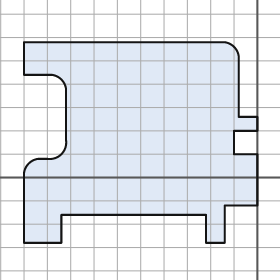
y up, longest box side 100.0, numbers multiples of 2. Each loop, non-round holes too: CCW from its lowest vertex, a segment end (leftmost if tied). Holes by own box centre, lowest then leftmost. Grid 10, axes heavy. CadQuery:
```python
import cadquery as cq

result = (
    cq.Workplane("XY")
    .moveTo(-100.0, -28.0)
    .lineTo(-84.0, -28.0)
    .lineTo(-84.0, -16.0)
    .lineTo(-22.0, -16.0)
    .lineTo(-22.0, -28.0)
    .lineTo(-14.0, -28.0)
    .lineTo(-14.0, -12.0)
    .lineTo(0.0, -12.0)
    .lineTo(0.0, 10.0)
    .lineTo(-10.0, 10.0)
    .lineTo(-10.0, 20.0)
    .lineTo(0.0, 20.0)
    .lineTo(0.0, 26.0)
    .lineTo(-8.0, 26.0)
    .lineTo(-8.0, 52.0)
    .threePointArc((-10.0, 56.0), (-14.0, 58.0))
    .lineTo(-100.0, 58.0)
    .lineTo(-100.0, 44.0)
    .lineTo(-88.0, 44.0)
    .threePointArc((-84.0, 42.0), (-82.0, 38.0))
    .lineTo(-82.0, 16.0)
    .threePointArc((-84.0, 10.0), (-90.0, 8.0))
    .lineTo(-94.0, 8.0)
    .threePointArc((-98.0, 6.0), (-100.0, 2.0))
    .close()
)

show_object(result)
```